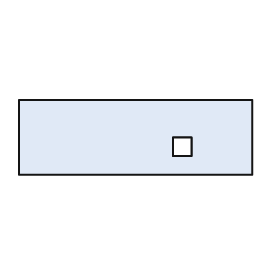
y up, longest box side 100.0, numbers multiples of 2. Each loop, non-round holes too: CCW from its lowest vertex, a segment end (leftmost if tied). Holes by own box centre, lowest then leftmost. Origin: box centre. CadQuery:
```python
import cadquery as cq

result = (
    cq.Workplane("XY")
    .moveTo(-50.0, -16.0)
    .lineTo(50.0, -16.0)
    .lineTo(50.0, 16.0)
    .lineTo(-50.0, 16.0)
    .close()
    .moveTo(16.0, -8.0)
    .lineTo(24.0, -8.0)
    .lineTo(24.0, 0.0)
    .lineTo(16.0, 0.0)
    .close()
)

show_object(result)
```